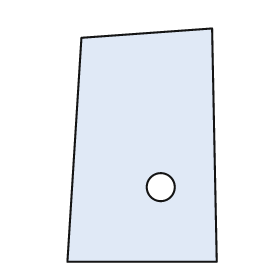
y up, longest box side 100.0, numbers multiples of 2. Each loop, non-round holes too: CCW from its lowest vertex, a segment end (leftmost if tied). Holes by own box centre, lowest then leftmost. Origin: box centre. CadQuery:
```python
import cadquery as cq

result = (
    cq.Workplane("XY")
    .moveTo(-32.0, -50.0)
    .lineTo(32.0, -50.0)
    .lineTo(30.0, 50.0)
    .lineTo(-26.0, 46.0)
    .close()
    .moveTo(8.0, -18.0)
    .circle(6.0)
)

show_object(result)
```